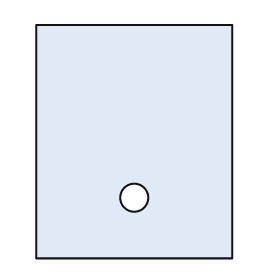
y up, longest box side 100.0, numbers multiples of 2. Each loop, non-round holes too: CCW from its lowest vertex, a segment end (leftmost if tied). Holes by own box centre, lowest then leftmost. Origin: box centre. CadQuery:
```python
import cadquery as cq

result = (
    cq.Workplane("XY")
    .moveTo(-42.0, -50.0)
    .lineTo(42.0, -50.0)
    .lineTo(42.0, 50.0)
    .lineTo(-42.0, 50.0)
    .close()
    .moveTo(0.0, -24.0)
    .circle(6.0)
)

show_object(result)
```